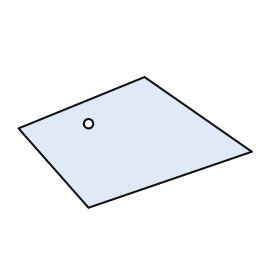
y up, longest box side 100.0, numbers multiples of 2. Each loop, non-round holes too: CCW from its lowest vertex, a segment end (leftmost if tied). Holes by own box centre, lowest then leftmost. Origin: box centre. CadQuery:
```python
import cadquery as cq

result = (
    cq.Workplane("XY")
    .moveTo(-20.0, -28.0)
    .lineTo(50.0, -4.0)
    .lineTo(4.0, 28.0)
    .lineTo(-50.0, 6.0)
    .close()
    .moveTo(-20.0, 8.0)
    .circle(2.0)
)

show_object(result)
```